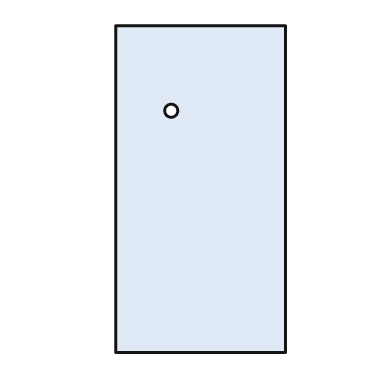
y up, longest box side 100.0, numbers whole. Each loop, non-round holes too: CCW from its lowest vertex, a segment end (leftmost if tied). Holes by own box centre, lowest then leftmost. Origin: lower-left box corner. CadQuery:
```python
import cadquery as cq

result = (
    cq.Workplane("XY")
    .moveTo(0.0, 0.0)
    .lineTo(52.0, 0.0)
    .lineTo(52.0, 100.0)
    .lineTo(0.0, 100.0)
    .close()
    .moveTo(17.0, 74.0)
    .circle(2.0)
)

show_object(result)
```